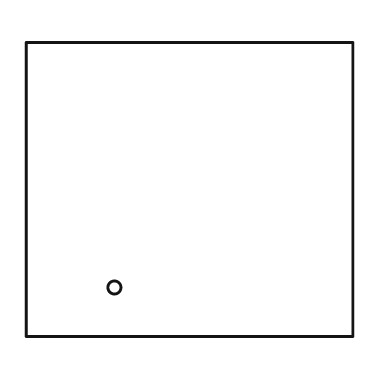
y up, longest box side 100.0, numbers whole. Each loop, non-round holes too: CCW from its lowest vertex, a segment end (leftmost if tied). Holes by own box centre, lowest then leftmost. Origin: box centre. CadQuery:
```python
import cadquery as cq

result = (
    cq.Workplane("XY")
    .moveTo(-50.0, -45.0)
    .lineTo(50.0, -45.0)
    .lineTo(50.0, 45.0)
    .lineTo(-50.0, 45.0)
    .close()
    .moveTo(-23.0, -30.0)
    .circle(2.0)
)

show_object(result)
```